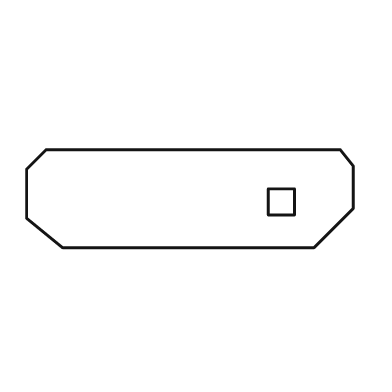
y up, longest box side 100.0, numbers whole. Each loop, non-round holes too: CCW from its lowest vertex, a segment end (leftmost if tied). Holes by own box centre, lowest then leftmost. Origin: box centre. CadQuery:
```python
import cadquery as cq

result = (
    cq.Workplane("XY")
    .moveTo(-39.0, -15.0)
    .lineTo(38.0, -15.0)
    .lineTo(50.0, -3.0)
    .lineTo(50.0, 10.0)
    .lineTo(46.0, 15.0)
    .lineTo(-44.0, 15.0)
    .lineTo(-50.0, 9.0)
    .lineTo(-50.0, -6.0)
    .close()
    .moveTo(24.0, -5.0)
    .lineTo(32.0, -5.0)
    .lineTo(32.0, 3.0)
    .lineTo(24.0, 3.0)
    .close()
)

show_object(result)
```